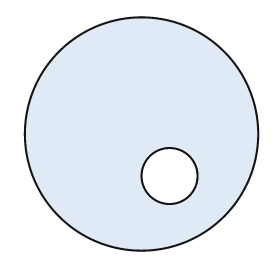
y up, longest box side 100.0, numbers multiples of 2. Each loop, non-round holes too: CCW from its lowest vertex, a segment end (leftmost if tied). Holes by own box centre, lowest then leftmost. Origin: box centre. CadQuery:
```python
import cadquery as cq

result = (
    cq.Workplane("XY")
    .moveTo(0.0, 0.0)
    .circle(50.0)
    .moveTo(12.0, -18.0)
    .circle(12.0)
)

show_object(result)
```